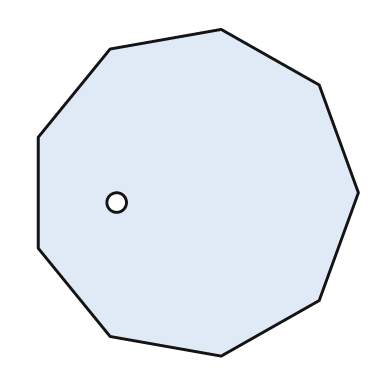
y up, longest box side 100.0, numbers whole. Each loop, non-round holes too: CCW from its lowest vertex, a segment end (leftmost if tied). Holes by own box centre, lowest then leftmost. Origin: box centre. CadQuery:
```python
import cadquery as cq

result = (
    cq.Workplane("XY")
    .moveTo(7.0, -50.0)
    .lineTo(37.0, -33.0)
    .lineTo(49.0, 0.0)
    .lineTo(37.0, 33.0)
    .lineTo(7.0, 50.0)
    .lineTo(-27.0, 44.0)
    .lineTo(-49.0, 17.0)
    .lineTo(-49.0, -17.0)
    .lineTo(-27.0, -44.0)
    .close()
    .moveTo(-25.0, -3.0)
    .circle(3.0)
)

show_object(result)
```